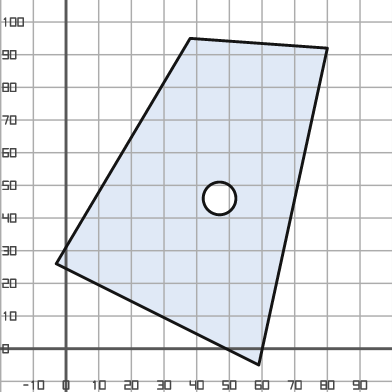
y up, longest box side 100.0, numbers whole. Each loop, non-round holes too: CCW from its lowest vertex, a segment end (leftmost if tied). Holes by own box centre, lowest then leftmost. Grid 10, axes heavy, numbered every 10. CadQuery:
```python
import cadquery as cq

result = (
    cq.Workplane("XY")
    .moveTo(59.0, -5.0)
    .lineTo(80.0, 92.0)
    .lineTo(38.0, 95.0)
    .lineTo(-3.0, 26.0)
    .close()
    .moveTo(47.0, 46.0)
    .circle(5.0)
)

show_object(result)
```